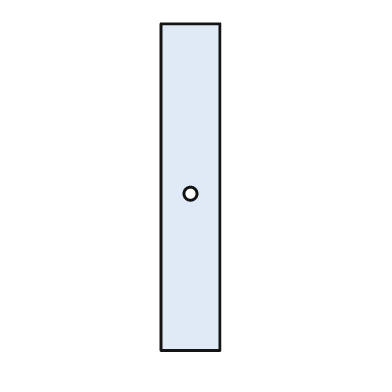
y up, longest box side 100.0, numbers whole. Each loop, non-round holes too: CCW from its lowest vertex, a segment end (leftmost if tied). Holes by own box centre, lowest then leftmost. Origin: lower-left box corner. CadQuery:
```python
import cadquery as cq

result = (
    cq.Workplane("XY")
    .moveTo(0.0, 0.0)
    .lineTo(18.0, 0.0)
    .lineTo(18.0, 100.0)
    .lineTo(0.0, 100.0)
    .close()
    .moveTo(9.0, 48.0)
    .circle(2.0)
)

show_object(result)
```